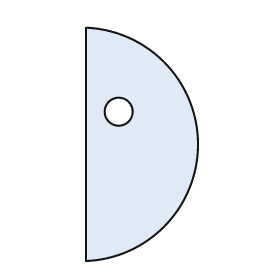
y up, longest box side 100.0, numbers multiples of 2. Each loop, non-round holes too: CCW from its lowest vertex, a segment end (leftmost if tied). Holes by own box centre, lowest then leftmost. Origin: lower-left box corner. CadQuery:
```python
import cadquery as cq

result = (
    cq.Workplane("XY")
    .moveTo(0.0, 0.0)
    .threePointArc((48.0, 50.0), (0.0, 100.0))
    .close()
    .moveTo(14.0, 64.0)
    .circle(6.0)
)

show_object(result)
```